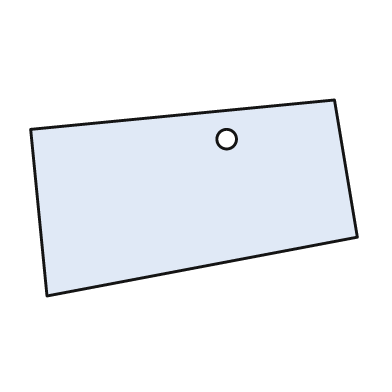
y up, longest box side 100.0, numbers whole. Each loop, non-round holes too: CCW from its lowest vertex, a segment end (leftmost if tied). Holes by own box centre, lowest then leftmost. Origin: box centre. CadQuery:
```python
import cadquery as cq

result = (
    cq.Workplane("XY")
    .moveTo(-45.0, -30.0)
    .lineTo(50.0, -12.0)
    .lineTo(43.0, 30.0)
    .lineTo(-50.0, 21.0)
    .close()
    .moveTo(10.0, 18.0)
    .circle(3.0)
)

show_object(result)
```